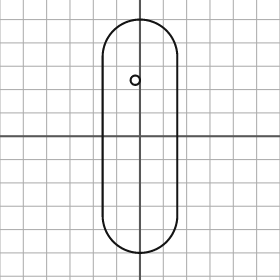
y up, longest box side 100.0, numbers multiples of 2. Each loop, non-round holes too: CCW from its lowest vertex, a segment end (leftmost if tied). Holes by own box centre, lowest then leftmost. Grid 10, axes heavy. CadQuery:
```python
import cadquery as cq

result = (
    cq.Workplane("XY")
    .moveTo(-16.0, -34.0)
    .threePointArc((0.0, -50.0), (16.0, -34.0))
    .lineTo(16.0, 34.0)
    .threePointArc((0.0, 50.0), (-16.0, 34.0))
    .close()
    .moveTo(-2.0, 24.0)
    .circle(2.0)
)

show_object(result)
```